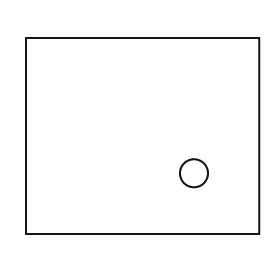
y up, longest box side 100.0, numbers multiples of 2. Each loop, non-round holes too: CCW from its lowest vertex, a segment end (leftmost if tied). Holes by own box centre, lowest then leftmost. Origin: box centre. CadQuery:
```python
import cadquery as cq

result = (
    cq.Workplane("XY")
    .moveTo(-50.0, -42.0)
    .lineTo(50.0, -42.0)
    .lineTo(50.0, 42.0)
    .lineTo(-50.0, 42.0)
    .close()
    .moveTo(22.0, -16.0)
    .circle(6.0)
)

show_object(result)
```